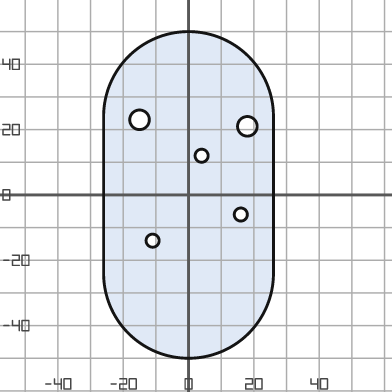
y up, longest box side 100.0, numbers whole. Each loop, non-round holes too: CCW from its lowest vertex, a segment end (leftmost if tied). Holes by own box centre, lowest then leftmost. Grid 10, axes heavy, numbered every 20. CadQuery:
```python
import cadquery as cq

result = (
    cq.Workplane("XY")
    .moveTo(-26.0, -24.0)
    .threePointArc((0.0, -50.0), (26.0, -24.0))
    .lineTo(26.0, 24.0)
    .threePointArc((0.0, 50.0), (-26.0, 24.0))
    .close()
    .moveTo(-11.0, -14.0)
    .circle(2.0)
    .moveTo(16.0, -6.0)
    .circle(2.0)
    .moveTo(4.0, 12.0)
    .circle(2.0)
    .moveTo(18.0, 21.0)
    .circle(3.0)
    .moveTo(-15.0, 23.0)
    .circle(3.0)
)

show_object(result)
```